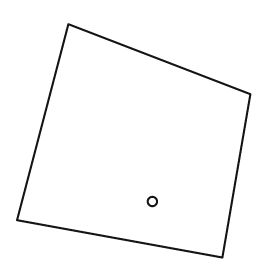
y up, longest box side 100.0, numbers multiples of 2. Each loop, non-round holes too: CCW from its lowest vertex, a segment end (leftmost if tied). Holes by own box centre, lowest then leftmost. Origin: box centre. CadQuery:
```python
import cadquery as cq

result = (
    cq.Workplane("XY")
    .moveTo(38.0, -50.0)
    .lineTo(50.0, 20.0)
    .lineTo(-28.0, 50.0)
    .lineTo(-50.0, -34.0)
    .close()
    .moveTo(8.0, -26.0)
    .circle(2.0)
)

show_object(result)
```